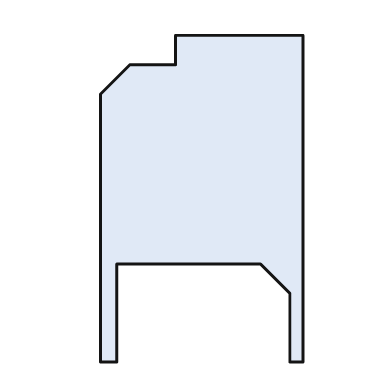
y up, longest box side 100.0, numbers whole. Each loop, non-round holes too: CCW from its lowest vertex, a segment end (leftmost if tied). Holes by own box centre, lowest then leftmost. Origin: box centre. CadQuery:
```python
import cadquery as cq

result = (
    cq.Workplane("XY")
    .moveTo(-31.0, -50.0)
    .lineTo(-26.0, -50.0)
    .lineTo(-26.0, -20.0)
    .lineTo(18.0, -20.0)
    .lineTo(27.0, -29.0)
    .lineTo(27.0, -50.0)
    .lineTo(31.0, -50.0)
    .lineTo(31.0, 50.0)
    .lineTo(-8.0, 50.0)
    .lineTo(-8.0, 41.0)
    .lineTo(-22.0, 41.0)
    .lineTo(-31.0, 32.0)
    .close()
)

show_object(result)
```